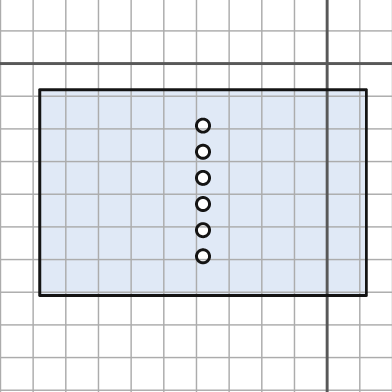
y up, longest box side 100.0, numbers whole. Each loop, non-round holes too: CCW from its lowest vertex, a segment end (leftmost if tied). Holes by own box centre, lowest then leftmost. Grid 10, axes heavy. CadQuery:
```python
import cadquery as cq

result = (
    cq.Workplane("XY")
    .moveTo(-88.0, -71.0)
    .lineTo(12.0, -71.0)
    .lineTo(12.0, -8.0)
    .lineTo(-88.0, -8.0)
    .close()
    .moveTo(-38.0, -59.0)
    .circle(2.0)
    .moveTo(-38.0, -51.0)
    .circle(2.0)
    .moveTo(-38.0, -43.0)
    .circle(2.0)
    .moveTo(-38.0, -35.0)
    .circle(2.0)
    .moveTo(-38.0, -27.0)
    .circle(2.0)
    .moveTo(-38.0, -19.0)
    .circle(2.0)
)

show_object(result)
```